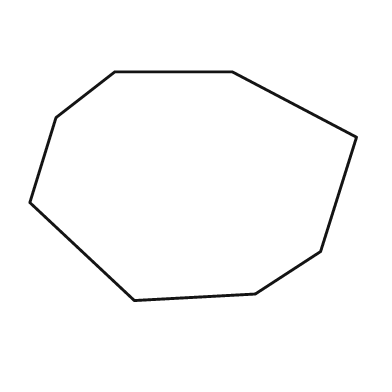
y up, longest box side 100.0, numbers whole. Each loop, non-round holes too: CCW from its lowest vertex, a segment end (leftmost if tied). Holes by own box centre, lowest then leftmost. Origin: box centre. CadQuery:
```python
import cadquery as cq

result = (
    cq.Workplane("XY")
    .moveTo(-18.0, -35.0)
    .lineTo(19.0, -33.0)
    .lineTo(39.0, -20.0)
    .lineTo(50.0, 15.0)
    .lineTo(12.0, 35.0)
    .lineTo(-24.0, 35.0)
    .lineTo(-42.0, 21.0)
    .lineTo(-50.0, -5.0)
    .close()
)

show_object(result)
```